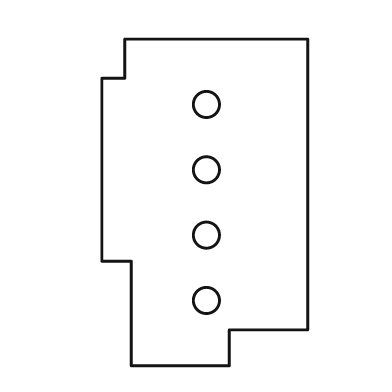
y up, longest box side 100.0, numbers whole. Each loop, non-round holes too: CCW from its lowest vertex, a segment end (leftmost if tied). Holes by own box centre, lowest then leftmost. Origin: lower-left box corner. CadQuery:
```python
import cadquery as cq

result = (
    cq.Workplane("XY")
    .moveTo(9.0, 0.0)
    .lineTo(39.0, 0.0)
    .lineTo(39.0, 11.0)
    .lineTo(63.0, 11.0)
    .lineTo(63.0, 100.0)
    .lineTo(7.0, 100.0)
    .lineTo(7.0, 88.0)
    .lineTo(0.0, 88.0)
    .lineTo(0.0, 32.0)
    .lineTo(9.0, 32.0)
    .close()
    .moveTo(32.0, 20.0)
    .circle(4.0)
    .moveTo(32.0, 40.0)
    .circle(4.0)
    .moveTo(32.0, 60.0)
    .circle(4.0)
    .moveTo(32.0, 80.0)
    .circle(4.0)
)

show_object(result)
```